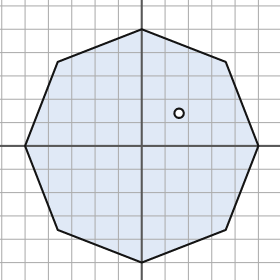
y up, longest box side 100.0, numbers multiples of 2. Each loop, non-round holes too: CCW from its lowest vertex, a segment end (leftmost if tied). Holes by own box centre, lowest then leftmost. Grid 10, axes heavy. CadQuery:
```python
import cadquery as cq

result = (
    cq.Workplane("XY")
    .moveTo(0.0, -50.0)
    .lineTo(36.0, -36.0)
    .lineTo(50.0, 0.0)
    .lineTo(36.0, 36.0)
    .lineTo(0.0, 50.0)
    .lineTo(-36.0, 36.0)
    .lineTo(-50.0, 0.0)
    .lineTo(-36.0, -36.0)
    .close()
    .moveTo(16.0, 14.0)
    .circle(2.0)
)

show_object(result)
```